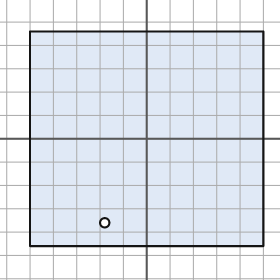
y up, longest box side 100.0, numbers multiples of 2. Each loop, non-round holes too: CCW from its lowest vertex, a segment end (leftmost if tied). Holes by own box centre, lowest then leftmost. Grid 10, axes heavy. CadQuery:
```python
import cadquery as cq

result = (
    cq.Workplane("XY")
    .moveTo(-50.0, -46.0)
    .lineTo(50.0, -46.0)
    .lineTo(50.0, 46.0)
    .lineTo(-50.0, 46.0)
    .close()
    .moveTo(-18.0, -36.0)
    .circle(2.0)
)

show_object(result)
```